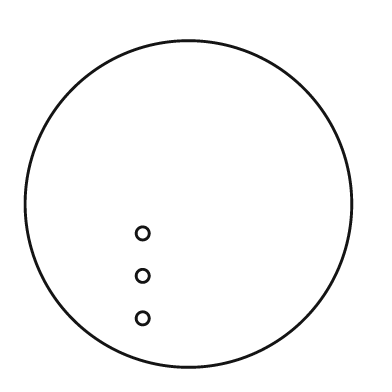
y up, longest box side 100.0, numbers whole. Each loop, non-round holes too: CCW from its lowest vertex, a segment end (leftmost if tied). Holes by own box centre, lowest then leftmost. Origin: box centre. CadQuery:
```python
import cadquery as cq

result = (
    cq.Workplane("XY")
    .moveTo(0.0, 0.0)
    .circle(50.0)
    .moveTo(-14.0, -35.0)
    .circle(2.0)
    .moveTo(-14.0, -22.0)
    .circle(2.0)
    .moveTo(-14.0, -9.0)
    .circle(2.0)
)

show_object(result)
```